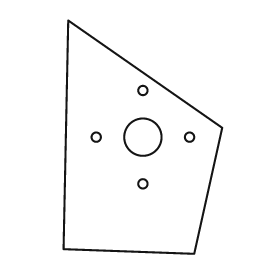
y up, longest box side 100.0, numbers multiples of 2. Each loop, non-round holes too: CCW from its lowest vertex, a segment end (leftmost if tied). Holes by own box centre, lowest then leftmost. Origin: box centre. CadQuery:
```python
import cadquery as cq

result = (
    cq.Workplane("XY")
    .moveTo(22.0, -50.0)
    .lineTo(34.0, 4.0)
    .lineTo(-32.0, 50.0)
    .lineTo(-34.0, -48.0)
    .close()
    .moveTo(0.0, -20.0)
    .circle(2.0)
    .moveTo(-20.0, 0.0)
    .circle(2.0)
    .moveTo(0.0, 0.0)
    .circle(8.0)
    .moveTo(20.0, 0.0)
    .circle(2.0)
    .moveTo(0.0, 20.0)
    .circle(2.0)
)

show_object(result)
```